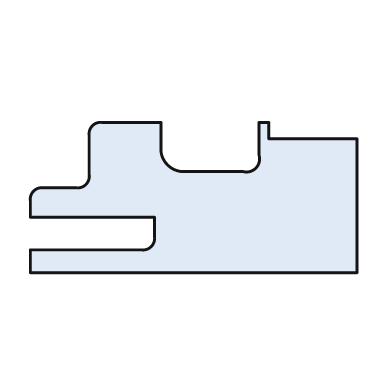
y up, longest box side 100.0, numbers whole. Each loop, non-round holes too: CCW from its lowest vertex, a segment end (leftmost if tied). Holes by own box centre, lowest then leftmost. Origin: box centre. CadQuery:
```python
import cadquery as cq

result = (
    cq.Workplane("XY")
    .moveTo(-50.0, -23.0)
    .lineTo(50.0, -23.0)
    .lineTo(50.0, 18.0)
    .lineTo(23.0, 18.0)
    .lineTo(23.0, 23.0)
    .lineTo(20.0, 23.0)
    .lineTo(20.0, 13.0)
    .threePointArc((19.0, 9.0), (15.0, 8.0))
    .lineTo(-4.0, 8.0)
    .threePointArc((-8.0, 10.0), (-10.0, 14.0))
    .lineTo(-10.0, 23.0)
    .lineTo(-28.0, 23.0)
    .threePointArc((-31.0, 22.0), (-32.0, 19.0))
    .lineTo(-32.0, 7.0)
    .threePointArc((-33.0, 4.0), (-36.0, 3.0))
    .lineTo(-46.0, 3.0)
    .threePointArc((-49.0, 2.0), (-50.0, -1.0))
    .lineTo(-50.0, -6.0)
    .lineTo(-12.0, -6.0)
    .lineTo(-12.0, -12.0)
    .threePointArc((-13.0, -15.0), (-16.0, -16.0))
    .lineTo(-50.0, -16.0)
    .close()
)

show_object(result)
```